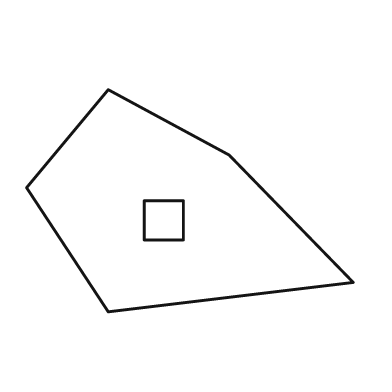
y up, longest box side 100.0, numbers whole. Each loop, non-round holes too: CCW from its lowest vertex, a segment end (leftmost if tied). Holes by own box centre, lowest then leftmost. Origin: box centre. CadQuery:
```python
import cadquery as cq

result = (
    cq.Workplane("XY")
    .moveTo(-25.0, -34.0)
    .lineTo(50.0, -25.0)
    .lineTo(12.0, 14.0)
    .lineTo(-25.0, 34.0)
    .lineTo(-50.0, 4.0)
    .close()
    .moveTo(-14.0, -12.0)
    .lineTo(-2.0, -12.0)
    .lineTo(-2.0, 0.0)
    .lineTo(-14.0, 0.0)
    .close()
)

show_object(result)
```